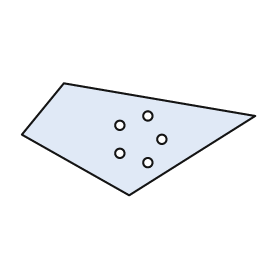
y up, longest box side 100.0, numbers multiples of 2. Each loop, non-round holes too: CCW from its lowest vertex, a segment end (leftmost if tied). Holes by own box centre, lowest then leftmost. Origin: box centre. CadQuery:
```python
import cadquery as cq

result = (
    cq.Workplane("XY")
    .moveTo(-4.0, -24.0)
    .lineTo(50.0, 10.0)
    .lineTo(-32.0, 24.0)
    .lineTo(-50.0, 2.0)
    .close()
    .moveTo(4.0, -10.0)
    .circle(2.0)
    .moveTo(-8.0, -6.0)
    .circle(2.0)
    .moveTo(10.0, 0.0)
    .circle(2.0)
    .moveTo(-8.0, 6.0)
    .circle(2.0)
    .moveTo(4.0, 10.0)
    .circle(2.0)
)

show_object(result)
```